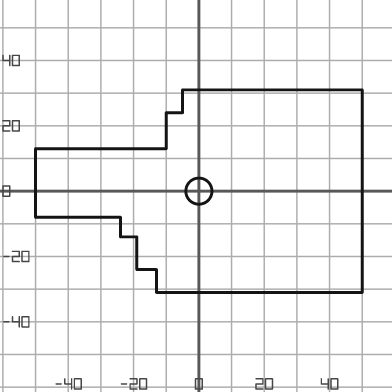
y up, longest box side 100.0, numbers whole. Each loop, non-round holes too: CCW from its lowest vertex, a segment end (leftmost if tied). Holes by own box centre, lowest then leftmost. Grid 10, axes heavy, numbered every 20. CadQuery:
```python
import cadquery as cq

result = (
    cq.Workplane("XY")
    .moveTo(-13.0, -31.0)
    .lineTo(50.0, -31.0)
    .lineTo(50.0, 31.0)
    .lineTo(-5.0, 31.0)
    .lineTo(-5.0, 24.0)
    .lineTo(-10.0, 24.0)
    .lineTo(-10.0, 13.0)
    .lineTo(-50.0, 13.0)
    .lineTo(-50.0, -8.0)
    .lineTo(-24.0, -8.0)
    .lineTo(-24.0, -14.0)
    .lineTo(-19.0, -14.0)
    .lineTo(-19.0, -24.0)
    .lineTo(-13.0, -24.0)
    .close()
    .moveTo(0.0, 0.0)
    .circle(4.0)
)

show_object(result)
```